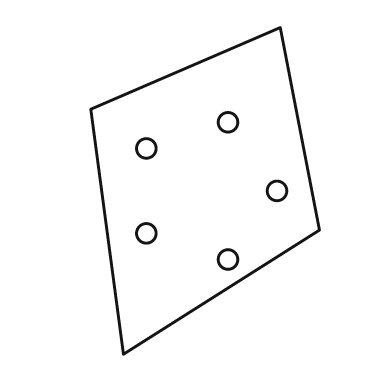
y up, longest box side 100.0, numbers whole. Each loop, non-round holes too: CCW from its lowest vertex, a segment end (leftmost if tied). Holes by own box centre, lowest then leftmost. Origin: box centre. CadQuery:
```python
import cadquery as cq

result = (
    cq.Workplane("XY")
    .moveTo(-25.0, -50.0)
    .lineTo(35.0, -12.0)
    .lineTo(23.0, 50.0)
    .lineTo(-35.0, 25.0)
    .close()
    .moveTo(7.0, -21.0)
    .circle(3.0)
    .moveTo(-18.0, -13.0)
    .circle(3.0)
    .moveTo(22.0, 0.0)
    .circle(3.0)
    .moveTo(-18.0, 13.0)
    .circle(3.0)
    .moveTo(7.0, 21.0)
    .circle(3.0)
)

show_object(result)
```